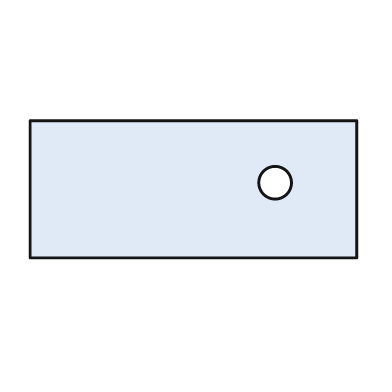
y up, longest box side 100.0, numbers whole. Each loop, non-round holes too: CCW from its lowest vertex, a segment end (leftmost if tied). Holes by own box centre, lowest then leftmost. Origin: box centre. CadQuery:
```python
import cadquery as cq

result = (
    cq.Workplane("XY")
    .moveTo(-50.0, -21.0)
    .lineTo(50.0, -21.0)
    .lineTo(50.0, 21.0)
    .lineTo(-50.0, 21.0)
    .close()
    .moveTo(25.0, 2.0)
    .circle(5.0)
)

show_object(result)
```